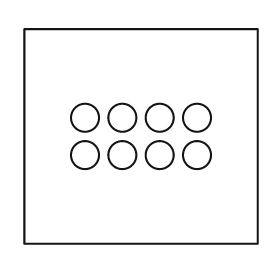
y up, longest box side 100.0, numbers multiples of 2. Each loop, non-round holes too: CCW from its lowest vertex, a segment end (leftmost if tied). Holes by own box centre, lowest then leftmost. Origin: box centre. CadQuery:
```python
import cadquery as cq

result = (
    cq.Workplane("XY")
    .moveTo(-50.0, -46.0)
    .lineTo(50.0, -46.0)
    .lineTo(50.0, 46.0)
    .lineTo(-50.0, 46.0)
    .close()
    .moveTo(-24.0, -8.0)
    .circle(6.0)
    .moveTo(-8.0, -8.0)
    .circle(6.0)
    .moveTo(8.0, -8.0)
    .circle(6.0)
    .moveTo(24.0, -8.0)
    .circle(6.0)
    .moveTo(-24.0, 8.0)
    .circle(6.0)
    .moveTo(-8.0, 8.0)
    .circle(6.0)
    .moveTo(8.0, 8.0)
    .circle(6.0)
    .moveTo(24.0, 8.0)
    .circle(6.0)
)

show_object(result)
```